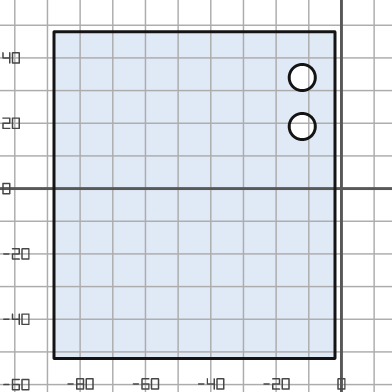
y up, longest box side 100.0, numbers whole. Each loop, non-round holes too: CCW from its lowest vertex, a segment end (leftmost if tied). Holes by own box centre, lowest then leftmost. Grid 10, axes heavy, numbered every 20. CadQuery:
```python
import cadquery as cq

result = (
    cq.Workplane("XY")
    .moveTo(-88.0, -52.0)
    .lineTo(-2.0, -52.0)
    .lineTo(-2.0, 48.0)
    .lineTo(-88.0, 48.0)
    .close()
    .moveTo(-12.0, 19.0)
    .circle(4.0)
    .moveTo(-12.0, 34.0)
    .circle(4.0)
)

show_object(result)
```